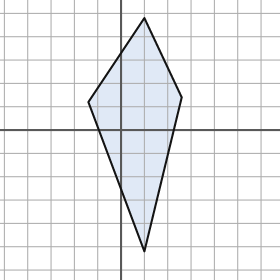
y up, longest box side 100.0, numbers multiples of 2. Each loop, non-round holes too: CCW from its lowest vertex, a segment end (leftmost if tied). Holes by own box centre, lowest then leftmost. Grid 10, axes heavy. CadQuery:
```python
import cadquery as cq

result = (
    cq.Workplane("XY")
    .moveTo(10.0, -52.0)
    .lineTo(26.0, 14.0)
    .lineTo(10.0, 48.0)
    .lineTo(-14.0, 12.0)
    .close()
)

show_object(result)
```